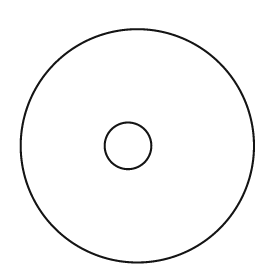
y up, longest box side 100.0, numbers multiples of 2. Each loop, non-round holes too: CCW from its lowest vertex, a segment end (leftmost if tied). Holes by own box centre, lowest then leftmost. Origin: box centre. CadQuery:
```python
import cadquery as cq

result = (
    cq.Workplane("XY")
    .moveTo(0.0, 0.0)
    .circle(50.0)
    .moveTo(-4.0, 0.0)
    .circle(10.0)
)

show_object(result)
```